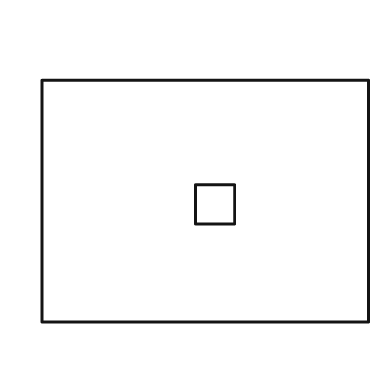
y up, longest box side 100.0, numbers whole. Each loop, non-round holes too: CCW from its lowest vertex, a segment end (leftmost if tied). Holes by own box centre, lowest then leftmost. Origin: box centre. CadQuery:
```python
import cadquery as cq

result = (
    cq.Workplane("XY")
    .moveTo(-50.0, -37.0)
    .lineTo(50.0, -37.0)
    .lineTo(50.0, 37.0)
    .lineTo(-50.0, 37.0)
    .close()
    .moveTo(-3.0, -7.0)
    .lineTo(9.0, -7.0)
    .lineTo(9.0, 5.0)
    .lineTo(-3.0, 5.0)
    .close()
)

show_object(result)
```